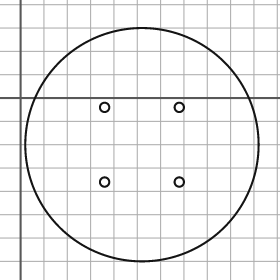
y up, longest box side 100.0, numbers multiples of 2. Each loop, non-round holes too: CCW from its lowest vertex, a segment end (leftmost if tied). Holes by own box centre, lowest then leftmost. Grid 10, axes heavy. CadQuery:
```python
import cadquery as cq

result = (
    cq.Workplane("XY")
    .moveTo(52.0, -20.0)
    .circle(50.0)
    .moveTo(36.0, -36.0)
    .circle(2.0)
    .moveTo(68.0, -36.0)
    .circle(2.0)
    .moveTo(36.0, -4.0)
    .circle(2.0)
    .moveTo(68.0, -4.0)
    .circle(2.0)
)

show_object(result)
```